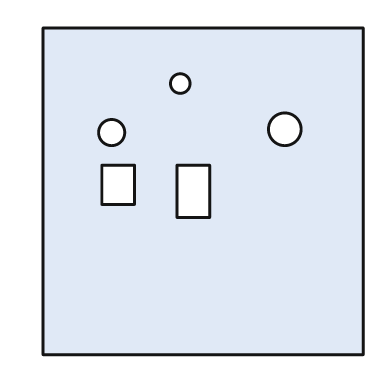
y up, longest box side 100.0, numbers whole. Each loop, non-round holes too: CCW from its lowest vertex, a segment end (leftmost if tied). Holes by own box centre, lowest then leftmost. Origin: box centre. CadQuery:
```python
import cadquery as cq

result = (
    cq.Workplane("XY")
    .moveTo(-49.0, -50.0)
    .lineTo(49.0, -50.0)
    .lineTo(49.0, 50.0)
    .lineTo(-49.0, 50.0)
    .close()
    .moveTo(-8.0, -8.0)
    .lineTo(2.0, -8.0)
    .lineTo(2.0, 8.0)
    .lineTo(-8.0, 8.0)
    .close()
    .moveTo(-31.0, -4.0)
    .lineTo(-21.0, -4.0)
    .lineTo(-21.0, 8.0)
    .lineTo(-31.0, 8.0)
    .close()
    .moveTo(-28.0, 18.0)
    .circle(4.0)
    .moveTo(25.0, 19.0)
    .circle(5.0)
    .moveTo(-7.0, 33.0)
    .circle(3.0)
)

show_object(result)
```